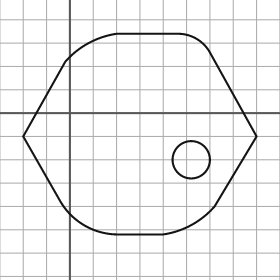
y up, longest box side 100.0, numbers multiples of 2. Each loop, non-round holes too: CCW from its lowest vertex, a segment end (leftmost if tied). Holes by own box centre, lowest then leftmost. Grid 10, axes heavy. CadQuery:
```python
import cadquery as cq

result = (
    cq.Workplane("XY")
    .moveTo(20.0, -52.0)
    .lineTo(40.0, -52.0)
    .threePointArc((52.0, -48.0), (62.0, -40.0))
    .lineTo(80.0, -10.0)
    .lineTo(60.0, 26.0)
    .threePointArc((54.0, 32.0), (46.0, 34.0))
    .lineTo(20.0, 34.0)
    .threePointArc((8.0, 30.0), (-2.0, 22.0))
    .lineTo(-20.0, -10.0)
    .lineTo(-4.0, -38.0)
    .threePointArc((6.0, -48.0), (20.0, -52.0))
    .close()
    .moveTo(52.0, -20.0)
    .circle(8.0)
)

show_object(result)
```